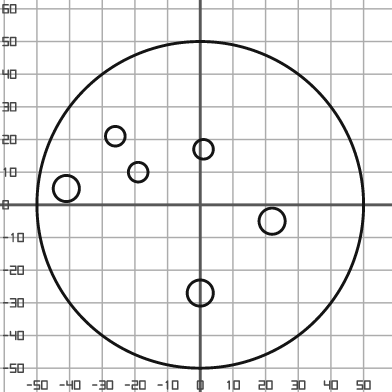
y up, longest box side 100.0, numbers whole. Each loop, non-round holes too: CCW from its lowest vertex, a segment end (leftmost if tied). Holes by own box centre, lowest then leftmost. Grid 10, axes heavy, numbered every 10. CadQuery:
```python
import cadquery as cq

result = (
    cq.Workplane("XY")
    .moveTo(0.0, 0.0)
    .circle(50.0)
    .moveTo(0.0, -27.0)
    .circle(4.0)
    .moveTo(22.0, -5.0)
    .circle(4.0)
    .moveTo(-41.0, 5.0)
    .circle(4.0)
    .moveTo(-19.0, 10.0)
    .circle(3.0)
    .moveTo(1.0, 17.0)
    .circle(3.0)
    .moveTo(-26.0, 21.0)
    .circle(3.0)
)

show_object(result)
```